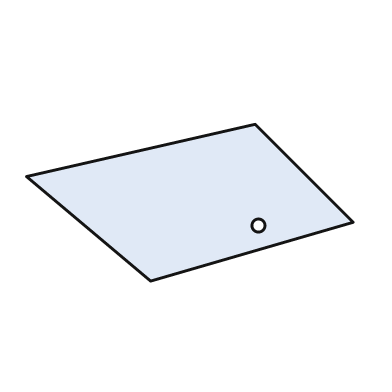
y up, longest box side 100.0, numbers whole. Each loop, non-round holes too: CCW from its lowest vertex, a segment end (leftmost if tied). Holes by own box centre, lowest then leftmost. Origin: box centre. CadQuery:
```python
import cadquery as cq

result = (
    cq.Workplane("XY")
    .moveTo(-12.0, -24.0)
    .lineTo(50.0, -6.0)
    .lineTo(20.0, 24.0)
    .lineTo(-50.0, 8.0)
    .close()
    .moveTo(21.0, -7.0)
    .circle(2.0)
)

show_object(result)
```